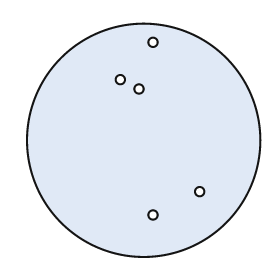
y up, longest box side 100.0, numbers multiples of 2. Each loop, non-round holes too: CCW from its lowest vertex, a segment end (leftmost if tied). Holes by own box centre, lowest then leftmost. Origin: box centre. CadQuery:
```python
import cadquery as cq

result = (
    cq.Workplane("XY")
    .moveTo(0.0, 0.0)
    .circle(50.0)
    .moveTo(4.0, -32.0)
    .circle(2.0)
    .moveTo(24.0, -22.0)
    .circle(2.0)
    .moveTo(-2.0, 22.0)
    .circle(2.0)
    .moveTo(-10.0, 26.0)
    .circle(2.0)
    .moveTo(4.0, 42.0)
    .circle(2.0)
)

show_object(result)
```